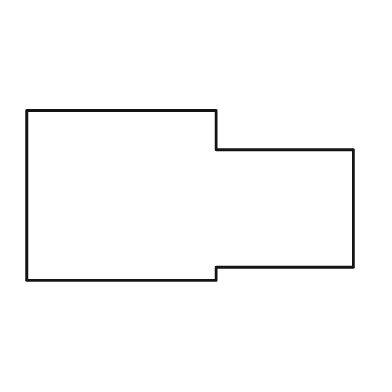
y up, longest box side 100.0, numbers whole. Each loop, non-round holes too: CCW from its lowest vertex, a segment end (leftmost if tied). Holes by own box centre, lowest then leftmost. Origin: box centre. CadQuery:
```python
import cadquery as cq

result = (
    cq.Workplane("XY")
    .moveTo(-50.0, -26.0)
    .lineTo(8.0, -26.0)
    .lineTo(8.0, -22.0)
    .lineTo(50.0, -22.0)
    .lineTo(50.0, 14.0)
    .lineTo(8.0, 14.0)
    .lineTo(8.0, 26.0)
    .lineTo(-50.0, 26.0)
    .close()
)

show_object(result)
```